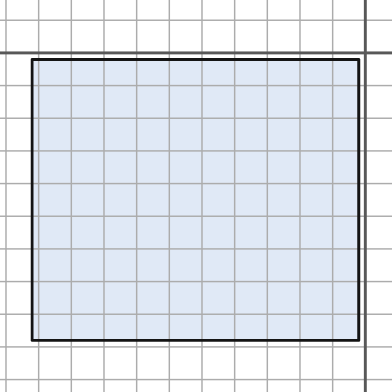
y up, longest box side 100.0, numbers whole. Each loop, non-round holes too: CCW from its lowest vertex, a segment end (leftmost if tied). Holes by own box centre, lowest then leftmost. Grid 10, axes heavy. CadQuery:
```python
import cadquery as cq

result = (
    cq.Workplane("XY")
    .moveTo(-102.0, -88.0)
    .lineTo(-2.0, -88.0)
    .lineTo(-2.0, -2.0)
    .lineTo(-102.0, -2.0)
    .close()
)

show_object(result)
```